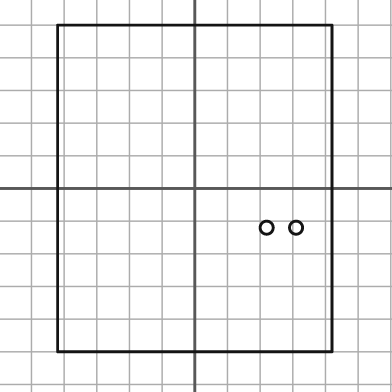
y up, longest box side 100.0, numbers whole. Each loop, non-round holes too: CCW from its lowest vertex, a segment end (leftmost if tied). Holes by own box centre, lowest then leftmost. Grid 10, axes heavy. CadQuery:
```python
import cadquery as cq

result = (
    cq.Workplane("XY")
    .moveTo(-42.0, -50.0)
    .lineTo(42.0, -50.0)
    .lineTo(42.0, 50.0)
    .lineTo(-42.0, 50.0)
    .close()
    .moveTo(22.0, -12.0)
    .circle(2.0)
    .moveTo(31.0, -12.0)
    .circle(2.0)
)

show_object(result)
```